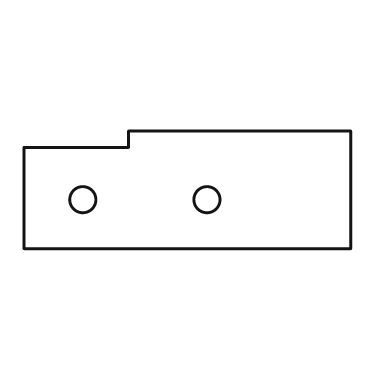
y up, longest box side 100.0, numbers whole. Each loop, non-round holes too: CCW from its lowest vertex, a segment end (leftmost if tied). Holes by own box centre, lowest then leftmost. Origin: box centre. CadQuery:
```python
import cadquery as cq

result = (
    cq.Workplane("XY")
    .moveTo(-50.0, -18.0)
    .lineTo(50.0, -18.0)
    .lineTo(50.0, 18.0)
    .lineTo(-18.0, 18.0)
    .lineTo(-18.0, 13.0)
    .lineTo(-50.0, 13.0)
    .close()
    .moveTo(-32.0, -3.0)
    .circle(4.0)
    .moveTo(6.0, -3.0)
    .circle(4.0)
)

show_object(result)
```